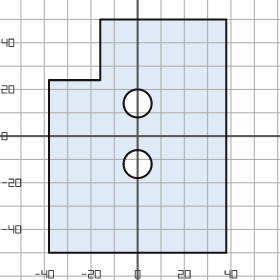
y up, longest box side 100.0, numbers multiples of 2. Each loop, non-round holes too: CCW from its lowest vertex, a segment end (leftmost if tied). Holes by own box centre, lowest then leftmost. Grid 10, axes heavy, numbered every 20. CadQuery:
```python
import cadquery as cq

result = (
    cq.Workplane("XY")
    .moveTo(-38.0, -50.0)
    .lineTo(38.0, -50.0)
    .lineTo(38.0, 50.0)
    .lineTo(-16.0, 50.0)
    .lineTo(-16.0, 24.0)
    .lineTo(-38.0, 24.0)
    .close()
    .moveTo(0.0, -12.0)
    .circle(6.0)
    .moveTo(0.0, 14.0)
    .circle(6.0)
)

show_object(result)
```